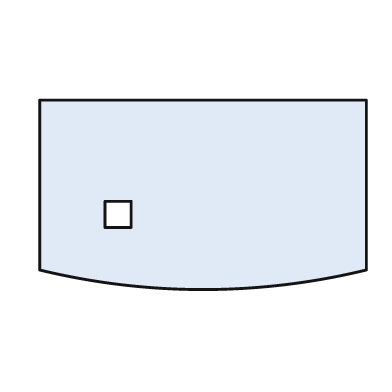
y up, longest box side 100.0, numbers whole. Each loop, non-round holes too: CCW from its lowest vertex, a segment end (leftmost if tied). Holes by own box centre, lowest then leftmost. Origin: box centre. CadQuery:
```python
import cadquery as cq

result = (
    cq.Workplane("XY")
    .moveTo(-50.0, -23.0)
    .threePointArc((0.0, -29.0), (50.0, -23.0))
    .lineTo(50.0, 29.0)
    .lineTo(-50.0, 29.0)
    .close()
    .moveTo(-30.0, -10.0)
    .lineTo(-22.0, -10.0)
    .lineTo(-22.0, -2.0)
    .lineTo(-30.0, -2.0)
    .close()
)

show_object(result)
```